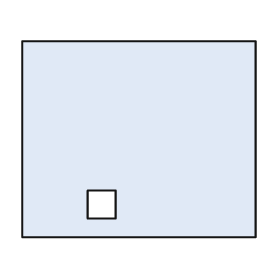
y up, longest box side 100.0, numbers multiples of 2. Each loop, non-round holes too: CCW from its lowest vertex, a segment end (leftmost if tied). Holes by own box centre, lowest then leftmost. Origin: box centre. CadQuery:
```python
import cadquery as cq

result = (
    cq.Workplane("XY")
    .moveTo(-50.0, -42.0)
    .lineTo(50.0, -42.0)
    .lineTo(50.0, 42.0)
    .lineTo(-50.0, 42.0)
    .close()
    .moveTo(-22.0, -34.0)
    .lineTo(-10.0, -34.0)
    .lineTo(-10.0, -22.0)
    .lineTo(-22.0, -22.0)
    .close()
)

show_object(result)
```